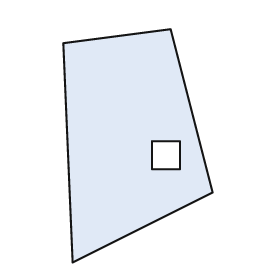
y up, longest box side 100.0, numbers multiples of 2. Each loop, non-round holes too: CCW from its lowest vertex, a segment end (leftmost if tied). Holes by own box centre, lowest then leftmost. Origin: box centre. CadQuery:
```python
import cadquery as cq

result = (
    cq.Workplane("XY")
    .moveTo(-28.0, -50.0)
    .lineTo(32.0, -20.0)
    .lineTo(14.0, 50.0)
    .lineTo(-32.0, 44.0)
    .close()
    .moveTo(6.0, -10.0)
    .lineTo(18.0, -10.0)
    .lineTo(18.0, 2.0)
    .lineTo(6.0, 2.0)
    .close()
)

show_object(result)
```